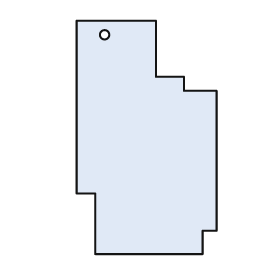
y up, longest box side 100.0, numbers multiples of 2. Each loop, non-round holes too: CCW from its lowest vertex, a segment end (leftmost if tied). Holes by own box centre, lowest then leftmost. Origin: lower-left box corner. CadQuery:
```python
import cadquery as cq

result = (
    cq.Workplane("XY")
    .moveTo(8.0, 0.0)
    .lineTo(54.0, 0.0)
    .lineTo(54.0, 10.0)
    .lineTo(60.0, 10.0)
    .lineTo(60.0, 70.0)
    .lineTo(46.0, 70.0)
    .lineTo(46.0, 76.0)
    .lineTo(34.0, 76.0)
    .lineTo(34.0, 100.0)
    .lineTo(0.0, 100.0)
    .lineTo(0.0, 26.0)
    .lineTo(8.0, 26.0)
    .close()
    .moveTo(12.0, 94.0)
    .circle(2.0)
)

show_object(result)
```